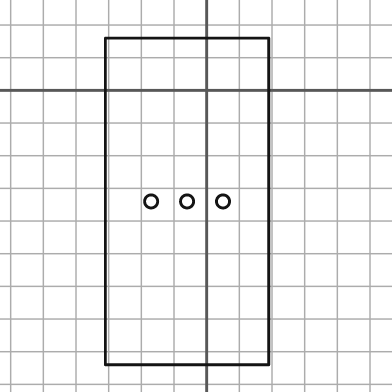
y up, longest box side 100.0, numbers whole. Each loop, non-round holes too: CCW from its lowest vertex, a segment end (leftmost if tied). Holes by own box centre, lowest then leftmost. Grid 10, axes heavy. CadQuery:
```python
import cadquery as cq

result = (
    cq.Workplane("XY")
    .moveTo(-31.0, -84.0)
    .lineTo(19.0, -84.0)
    .lineTo(19.0, 16.0)
    .lineTo(-31.0, 16.0)
    .close()
    .moveTo(-17.0, -34.0)
    .circle(2.0)
    .moveTo(-6.0, -34.0)
    .circle(2.0)
    .moveTo(5.0, -34.0)
    .circle(2.0)
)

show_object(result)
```